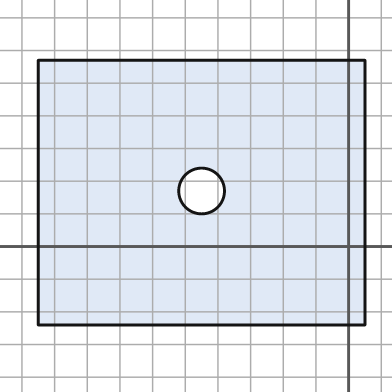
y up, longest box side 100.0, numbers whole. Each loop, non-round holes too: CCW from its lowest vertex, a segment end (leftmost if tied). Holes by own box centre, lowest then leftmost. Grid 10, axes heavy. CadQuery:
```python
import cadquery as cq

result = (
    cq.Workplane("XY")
    .moveTo(-95.0, -24.0)
    .lineTo(5.0, -24.0)
    .lineTo(5.0, 57.0)
    .lineTo(-95.0, 57.0)
    .close()
    .moveTo(-45.0, 17.0)
    .circle(7.0)
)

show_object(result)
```